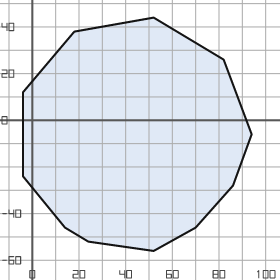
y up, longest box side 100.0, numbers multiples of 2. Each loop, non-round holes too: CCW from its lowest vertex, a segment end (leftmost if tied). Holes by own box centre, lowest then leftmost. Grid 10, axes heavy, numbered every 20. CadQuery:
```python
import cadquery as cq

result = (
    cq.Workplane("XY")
    .moveTo(52.0, -56.0)
    .lineTo(70.0, -46.0)
    .lineTo(86.0, -28.0)
    .lineTo(94.0, -6.0)
    .lineTo(82.0, 26.0)
    .lineTo(52.0, 44.0)
    .lineTo(18.0, 38.0)
    .lineTo(-4.0, 12.0)
    .lineTo(-4.0, -24.0)
    .lineTo(14.0, -46.0)
    .lineTo(24.0, -52.0)
    .close()
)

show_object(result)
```